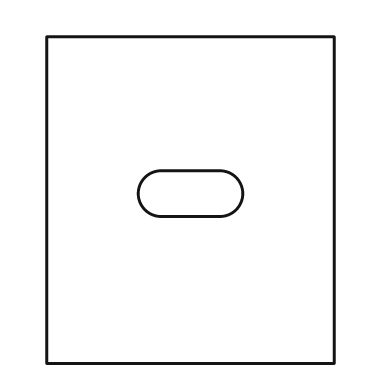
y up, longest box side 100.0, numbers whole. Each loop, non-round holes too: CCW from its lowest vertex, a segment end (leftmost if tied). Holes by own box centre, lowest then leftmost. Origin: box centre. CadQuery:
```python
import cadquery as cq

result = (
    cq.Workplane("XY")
    .moveTo(-44.0, -50.0)
    .lineTo(44.0, -50.0)
    .lineTo(44.0, 50.0)
    .lineTo(-44.0, 50.0)
    .close()
    .moveTo(-9.0, -5.0)
    .lineTo(9.0, -5.0)
    .threePointArc((16.0, 2.0), (9.0, 9.0))
    .lineTo(-9.0, 9.0)
    .threePointArc((-16.0, 2.0), (-9.0, -5.0))
    .close()
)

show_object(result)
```